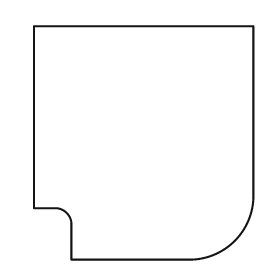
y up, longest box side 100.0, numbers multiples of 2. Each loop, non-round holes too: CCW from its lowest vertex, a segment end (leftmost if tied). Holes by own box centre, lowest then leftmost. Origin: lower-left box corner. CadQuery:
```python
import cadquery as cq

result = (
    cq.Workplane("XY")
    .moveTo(16.0, 0.0)
    .lineTo(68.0, 0.0)
    .threePointArc((86.0, 8.0), (94.0, 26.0))
    .lineTo(94.0, 100.0)
    .lineTo(0.0, 100.0)
    .lineTo(0.0, 22.0)
    .lineTo(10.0, 22.0)
    .threePointArc((14.0, 20.0), (16.0, 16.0))
    .close()
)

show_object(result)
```